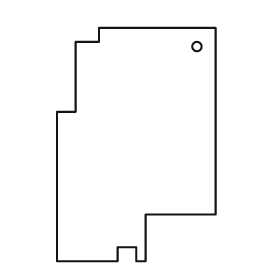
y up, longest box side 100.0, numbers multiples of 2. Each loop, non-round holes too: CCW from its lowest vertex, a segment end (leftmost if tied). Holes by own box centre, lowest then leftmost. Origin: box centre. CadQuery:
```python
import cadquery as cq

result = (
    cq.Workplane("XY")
    .moveTo(-34.0, -50.0)
    .lineTo(-8.0, -50.0)
    .lineTo(-8.0, -44.0)
    .lineTo(0.0, -44.0)
    .lineTo(0.0, -50.0)
    .lineTo(4.0, -50.0)
    .lineTo(4.0, -30.0)
    .lineTo(34.0, -30.0)
    .lineTo(34.0, 50.0)
    .lineTo(-16.0, 50.0)
    .lineTo(-16.0, 44.0)
    .lineTo(-26.0, 44.0)
    .lineTo(-26.0, 14.0)
    .lineTo(-34.0, 14.0)
    .close()
    .moveTo(26.0, 42.0)
    .circle(2.0)
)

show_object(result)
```